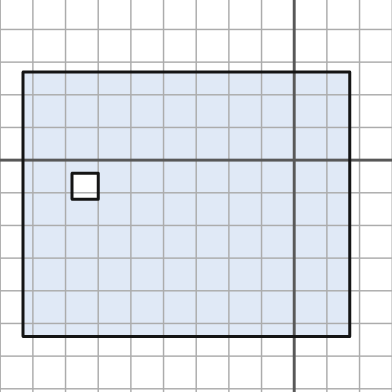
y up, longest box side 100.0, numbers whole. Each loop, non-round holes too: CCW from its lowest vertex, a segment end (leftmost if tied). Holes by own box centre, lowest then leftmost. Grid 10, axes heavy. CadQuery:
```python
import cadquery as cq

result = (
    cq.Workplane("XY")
    .moveTo(-83.0, -54.0)
    .lineTo(17.0, -54.0)
    .lineTo(17.0, 27.0)
    .lineTo(-83.0, 27.0)
    .close()
    .moveTo(-68.0, -12.0)
    .lineTo(-60.0, -12.0)
    .lineTo(-60.0, -4.0)
    .lineTo(-68.0, -4.0)
    .close()
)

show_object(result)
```